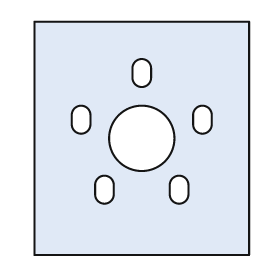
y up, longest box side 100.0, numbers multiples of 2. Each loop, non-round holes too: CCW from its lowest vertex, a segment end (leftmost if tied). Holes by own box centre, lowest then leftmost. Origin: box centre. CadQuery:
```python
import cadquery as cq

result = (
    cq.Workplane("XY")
    .moveTo(-46.0, -50.0)
    .lineTo(46.0, -50.0)
    .lineTo(46.0, 50.0)
    .lineTo(-46.0, 50.0)
    .close()
    .moveTo(-20.0, -24.0)
    .threePointArc((-16.0, -28.0), (-12.0, -24.0))
    .lineTo(-12.0, -20.0)
    .threePointArc((-16.0, -16.0), (-20.0, -20.0))
    .close()
    .moveTo(12.0, -24.0)
    .threePointArc((16.0, -28.0), (20.0, -24.0))
    .lineTo(20.0, -20.0)
    .threePointArc((16.0, -16.0), (12.0, -20.0))
    .close()
    .moveTo(0.0, 0.0)
    .circle(14.0)
    .moveTo(-30.0, 6.0)
    .threePointArc((-26.0, 2.0), (-22.0, 6.0))
    .lineTo(-22.0, 10.0)
    .threePointArc((-26.0, 14.0), (-30.0, 10.0))
    .close()
    .moveTo(22.0, 6.0)
    .threePointArc((26.0, 2.0), (30.0, 6.0))
    .lineTo(30.0, 10.0)
    .threePointArc((26.0, 14.0), (22.0, 10.0))
    .close()
    .moveTo(-4.0, 26.0)
    .threePointArc((0.0, 22.0), (4.0, 26.0))
    .lineTo(4.0, 30.0)
    .threePointArc((0.0, 34.0), (-4.0, 30.0))
    .close()
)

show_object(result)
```